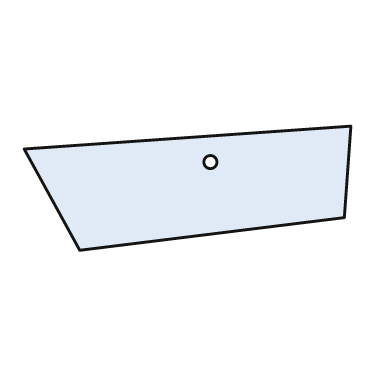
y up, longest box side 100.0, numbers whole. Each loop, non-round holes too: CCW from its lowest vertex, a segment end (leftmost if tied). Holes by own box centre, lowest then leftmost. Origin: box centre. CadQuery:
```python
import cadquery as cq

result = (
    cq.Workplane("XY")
    .moveTo(-33.0, -19.0)
    .lineTo(48.0, -9.0)
    .lineTo(50.0, 19.0)
    .lineTo(-50.0, 12.0)
    .close()
    .moveTo(7.0, 8.0)
    .circle(2.0)
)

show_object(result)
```